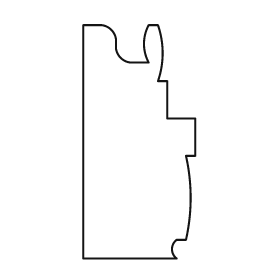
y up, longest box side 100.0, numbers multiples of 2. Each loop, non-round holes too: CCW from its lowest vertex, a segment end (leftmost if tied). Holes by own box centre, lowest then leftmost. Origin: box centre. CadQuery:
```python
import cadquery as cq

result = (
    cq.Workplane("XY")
    .moveTo(-24.0, -50.0)
    .lineTo(16.0, -50.0)
    .threePointArc((14.0, -46.0), (16.0, -42.0))
    .lineTo(20.0, -42.0)
    .threePointArc((22.0, -24.0), (20.0, -6.0))
    .lineTo(24.0, -6.0)
    .lineTo(24.0, 10.0)
    .lineTo(12.0, 10.0)
    .lineTo(12.0, 26.0)
    .lineTo(8.0, 26.0)
    .threePointArc((10.0, 38.0), (8.0, 50.0))
    .lineTo(4.0, 50.0)
    .threePointArc((2.0, 42.0), (4.0, 34.0))
    .lineTo(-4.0, 34.0)
    .threePointArc((-8.0, 36.0), (-10.0, 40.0))
    .lineTo(-10.0, 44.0)
    .threePointArc((-12.0, 48.0), (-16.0, 50.0))
    .lineTo(-24.0, 50.0)
    .close()
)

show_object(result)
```